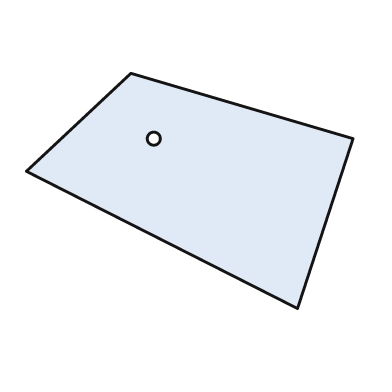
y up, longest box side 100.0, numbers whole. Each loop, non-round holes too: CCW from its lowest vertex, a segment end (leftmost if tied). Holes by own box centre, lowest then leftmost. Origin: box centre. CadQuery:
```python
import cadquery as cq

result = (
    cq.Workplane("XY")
    .moveTo(33.0, -36.0)
    .lineTo(50.0, 16.0)
    .lineTo(-18.0, 36.0)
    .lineTo(-50.0, 6.0)
    .close()
    .moveTo(-11.0, 16.0)
    .circle(2.0)
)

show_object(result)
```